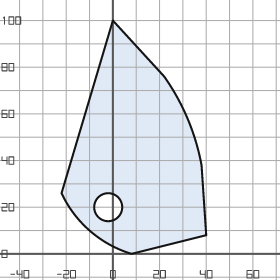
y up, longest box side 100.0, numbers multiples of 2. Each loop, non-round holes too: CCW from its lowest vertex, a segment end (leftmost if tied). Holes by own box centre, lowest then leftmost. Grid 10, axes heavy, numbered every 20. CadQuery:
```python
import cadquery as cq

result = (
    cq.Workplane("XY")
    .moveTo(8.0, 0.0)
    .lineTo(40.0, 8.0)
    .lineTo(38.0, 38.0)
    .threePointArc((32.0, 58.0), (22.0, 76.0))
    .lineTo(0.0, 100.0)
    .lineTo(-22.0, 26.0)
    .threePointArc((-10.0, 10.0), (8.0, 0.0))
    .close()
    .moveTo(-2.0, 20.0)
    .circle(6.0)
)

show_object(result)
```